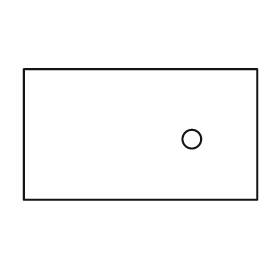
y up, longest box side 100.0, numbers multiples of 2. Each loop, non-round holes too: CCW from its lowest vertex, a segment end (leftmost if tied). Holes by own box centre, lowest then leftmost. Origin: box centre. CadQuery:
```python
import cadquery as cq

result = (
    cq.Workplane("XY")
    .moveTo(-50.0, -28.0)
    .lineTo(50.0, -28.0)
    .lineTo(50.0, 28.0)
    .lineTo(-50.0, 28.0)
    .close()
    .moveTo(22.0, -2.0)
    .circle(4.0)
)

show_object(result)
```